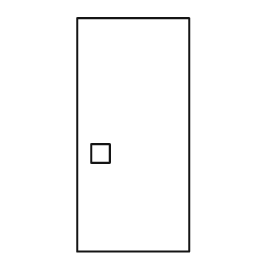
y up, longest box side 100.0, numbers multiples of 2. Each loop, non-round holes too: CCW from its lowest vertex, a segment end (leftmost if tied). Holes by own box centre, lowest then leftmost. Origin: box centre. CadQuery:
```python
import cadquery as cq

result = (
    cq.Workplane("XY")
    .moveTo(-24.0, -50.0)
    .lineTo(24.0, -50.0)
    .lineTo(24.0, 50.0)
    .lineTo(-24.0, 50.0)
    .close()
    .moveTo(-18.0, -12.0)
    .lineTo(-10.0, -12.0)
    .lineTo(-10.0, -4.0)
    .lineTo(-18.0, -4.0)
    .close()
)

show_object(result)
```